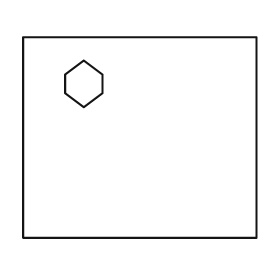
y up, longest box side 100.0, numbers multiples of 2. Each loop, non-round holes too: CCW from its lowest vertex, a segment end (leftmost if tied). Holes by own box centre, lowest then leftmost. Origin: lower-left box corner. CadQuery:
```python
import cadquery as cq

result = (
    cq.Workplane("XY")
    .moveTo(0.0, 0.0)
    .lineTo(100.0, 0.0)
    .lineTo(100.0, 86.0)
    .lineTo(0.0, 86.0)
    .close()
    .moveTo(26.0, 56.0)
    .lineTo(34.0, 62.0)
    .lineTo(34.0, 70.0)
    .lineTo(26.0, 76.0)
    .lineTo(18.0, 70.0)
    .lineTo(18.0, 62.0)
    .close()
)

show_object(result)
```